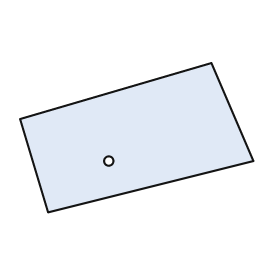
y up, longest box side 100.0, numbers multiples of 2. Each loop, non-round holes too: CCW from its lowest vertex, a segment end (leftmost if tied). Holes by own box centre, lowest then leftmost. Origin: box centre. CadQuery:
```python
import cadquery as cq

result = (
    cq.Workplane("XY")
    .moveTo(-38.0, -32.0)
    .lineTo(50.0, -10.0)
    .lineTo(32.0, 32.0)
    .lineTo(-50.0, 8.0)
    .close()
    .moveTo(-12.0, -10.0)
    .circle(2.0)
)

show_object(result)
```